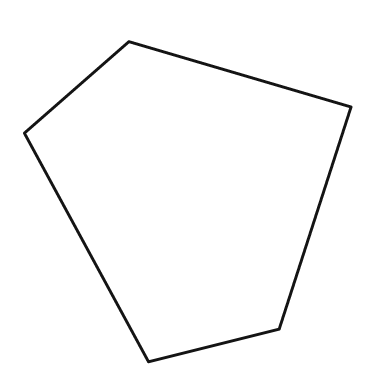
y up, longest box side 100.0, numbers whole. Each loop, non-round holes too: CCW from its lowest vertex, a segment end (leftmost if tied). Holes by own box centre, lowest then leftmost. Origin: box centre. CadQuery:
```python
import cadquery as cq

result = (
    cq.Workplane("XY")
    .moveTo(-12.0, -49.0)
    .lineTo(28.0, -39.0)
    .lineTo(50.0, 29.0)
    .lineTo(-18.0, 49.0)
    .lineTo(-50.0, 21.0)
    .close()
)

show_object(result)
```